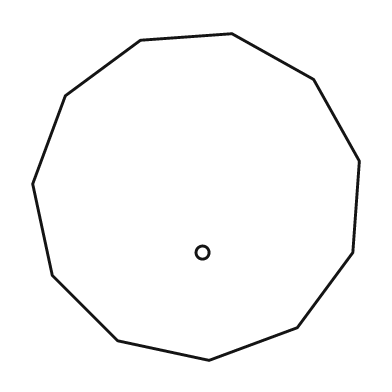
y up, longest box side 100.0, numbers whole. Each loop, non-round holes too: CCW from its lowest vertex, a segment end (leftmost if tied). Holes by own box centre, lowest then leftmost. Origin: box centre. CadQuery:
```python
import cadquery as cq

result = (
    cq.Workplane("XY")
    .moveTo(4.0, -50.0)
    .lineTo(31.0, -40.0)
    .lineTo(48.0, -17.0)
    .lineTo(50.0, 11.0)
    .lineTo(36.0, 36.0)
    .lineTo(11.0, 50.0)
    .lineTo(-17.0, 48.0)
    .lineTo(-40.0, 31.0)
    .lineTo(-50.0, 4.0)
    .lineTo(-44.0, -24.0)
    .lineTo(-24.0, -44.0)
    .close()
    .moveTo(2.0, -17.0)
    .circle(2.0)
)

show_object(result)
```